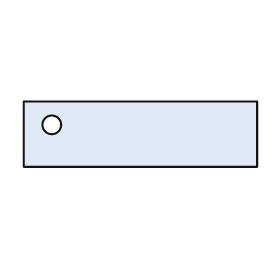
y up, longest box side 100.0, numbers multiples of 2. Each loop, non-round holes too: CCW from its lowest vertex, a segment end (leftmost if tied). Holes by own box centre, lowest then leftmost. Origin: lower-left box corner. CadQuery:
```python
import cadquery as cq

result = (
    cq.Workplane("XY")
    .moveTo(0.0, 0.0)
    .lineTo(100.0, 0.0)
    .lineTo(100.0, 28.0)
    .lineTo(0.0, 28.0)
    .close()
    .moveTo(12.0, 18.0)
    .circle(4.0)
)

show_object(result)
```